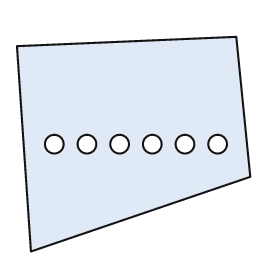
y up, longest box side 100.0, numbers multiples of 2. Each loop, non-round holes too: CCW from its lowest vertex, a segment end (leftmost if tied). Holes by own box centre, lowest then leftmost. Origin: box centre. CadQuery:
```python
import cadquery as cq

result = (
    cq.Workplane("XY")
    .moveTo(-44.0, -46.0)
    .lineTo(50.0, -14.0)
    .lineTo(44.0, 46.0)
    .lineTo(-50.0, 42.0)
    .close()
    .moveTo(-34.0, 0.0)
    .circle(4.0)
    .moveTo(-20.0, 0.0)
    .circle(4.0)
    .moveTo(-6.0, 0.0)
    .circle(4.0)
    .moveTo(8.0, 0.0)
    .circle(4.0)
    .moveTo(22.0, 0.0)
    .circle(4.0)
    .moveTo(36.0, 0.0)
    .circle(4.0)
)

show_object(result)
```